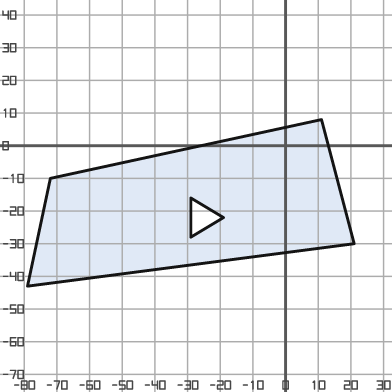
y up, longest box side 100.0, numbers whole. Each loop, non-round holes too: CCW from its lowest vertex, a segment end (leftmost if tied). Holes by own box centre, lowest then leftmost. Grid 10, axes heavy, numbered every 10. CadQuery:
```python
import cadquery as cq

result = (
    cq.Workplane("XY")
    .moveTo(-79.0, -43.0)
    .lineTo(21.0, -30.0)
    .lineTo(11.0, 8.0)
    .lineTo(-72.0, -10.0)
    .close()
    .moveTo(-29.0, -28.0)
    .lineTo(-19.0, -22.0)
    .lineTo(-29.0, -16.0)
    .close()
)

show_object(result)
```